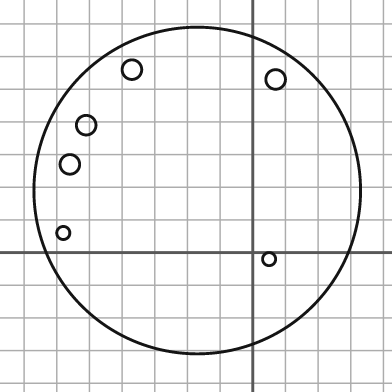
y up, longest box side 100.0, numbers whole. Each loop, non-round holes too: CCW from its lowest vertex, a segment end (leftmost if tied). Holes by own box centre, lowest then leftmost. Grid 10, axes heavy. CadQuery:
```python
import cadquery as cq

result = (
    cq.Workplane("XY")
    .moveTo(-17.0, 19.0)
    .circle(50.0)
    .moveTo(5.0, -2.0)
    .circle(2.0)
    .moveTo(-58.0, 6.0)
    .circle(2.0)
    .moveTo(-56.0, 27.0)
    .circle(3.0)
    .moveTo(-51.0, 39.0)
    .circle(3.0)
    .moveTo(7.0, 53.0)
    .circle(3.0)
    .moveTo(-37.0, 56.0)
    .circle(3.0)
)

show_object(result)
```